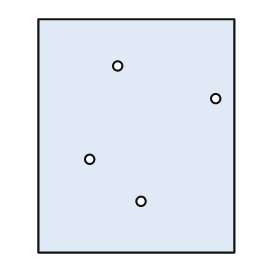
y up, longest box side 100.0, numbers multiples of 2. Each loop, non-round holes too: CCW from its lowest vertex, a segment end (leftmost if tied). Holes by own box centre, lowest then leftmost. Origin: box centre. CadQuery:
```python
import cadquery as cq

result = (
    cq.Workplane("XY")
    .moveTo(-42.0, -50.0)
    .lineTo(42.0, -50.0)
    .lineTo(42.0, 50.0)
    .lineTo(-42.0, 50.0)
    .close()
    .moveTo(2.0, -28.0)
    .circle(2.0)
    .moveTo(-20.0, -10.0)
    .circle(2.0)
    .moveTo(34.0, 16.0)
    .circle(2.0)
    .moveTo(-8.0, 30.0)
    .circle(2.0)
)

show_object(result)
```